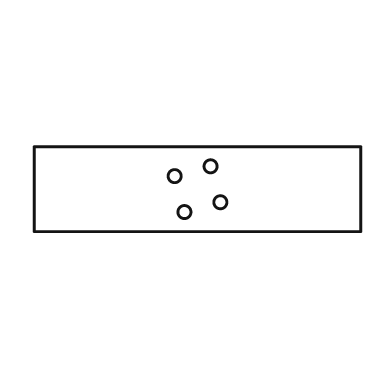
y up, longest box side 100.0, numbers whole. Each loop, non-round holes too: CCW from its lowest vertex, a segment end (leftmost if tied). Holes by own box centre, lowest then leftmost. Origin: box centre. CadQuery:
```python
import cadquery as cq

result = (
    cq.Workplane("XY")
    .moveTo(-50.0, -13.0)
    .lineTo(50.0, -13.0)
    .lineTo(50.0, 13.0)
    .lineTo(-50.0, 13.0)
    .close()
    .moveTo(-4.0, -7.0)
    .circle(2.0)
    .moveTo(7.0, -4.0)
    .circle(2.0)
    .moveTo(-7.0, 4.0)
    .circle(2.0)
    .moveTo(4.0, 7.0)
    .circle(2.0)
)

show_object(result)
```